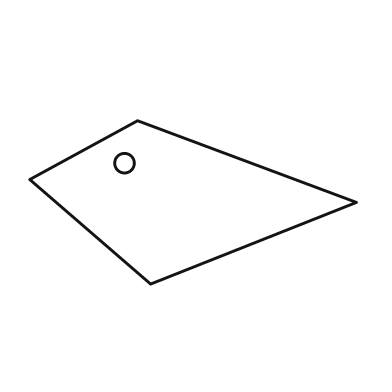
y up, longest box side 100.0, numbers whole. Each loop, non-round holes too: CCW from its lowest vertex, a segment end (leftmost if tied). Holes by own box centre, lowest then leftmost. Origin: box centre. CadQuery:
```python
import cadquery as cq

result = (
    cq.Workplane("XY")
    .moveTo(-13.0, -25.0)
    .lineTo(50.0, 0.0)
    .lineTo(-17.0, 25.0)
    .lineTo(-50.0, 7.0)
    .close()
    .moveTo(-21.0, 12.0)
    .circle(3.0)
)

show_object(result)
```